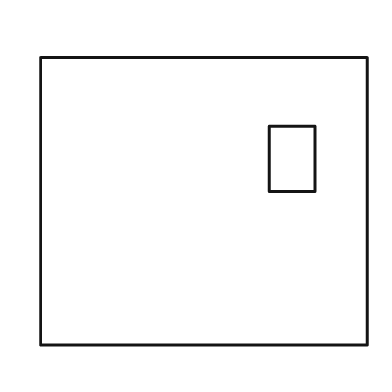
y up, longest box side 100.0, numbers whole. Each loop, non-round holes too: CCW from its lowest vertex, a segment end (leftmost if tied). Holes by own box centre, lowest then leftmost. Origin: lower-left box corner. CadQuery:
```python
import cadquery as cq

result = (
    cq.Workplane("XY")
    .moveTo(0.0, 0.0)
    .lineTo(100.0, 0.0)
    .lineTo(100.0, 88.0)
    .lineTo(0.0, 88.0)
    .close()
    .moveTo(70.0, 47.0)
    .lineTo(84.0, 47.0)
    .lineTo(84.0, 67.0)
    .lineTo(70.0, 67.0)
    .close()
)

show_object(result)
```